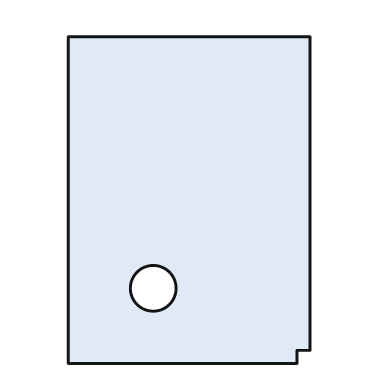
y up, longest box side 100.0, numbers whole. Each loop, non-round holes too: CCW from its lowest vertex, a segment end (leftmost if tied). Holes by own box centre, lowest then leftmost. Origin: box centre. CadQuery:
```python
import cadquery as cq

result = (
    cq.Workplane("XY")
    .moveTo(-37.0, -50.0)
    .lineTo(33.0, -50.0)
    .lineTo(33.0, -46.0)
    .lineTo(37.0, -46.0)
    .lineTo(37.0, 50.0)
    .lineTo(-37.0, 50.0)
    .close()
    .moveTo(-11.0, -27.0)
    .circle(7.0)
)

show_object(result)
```